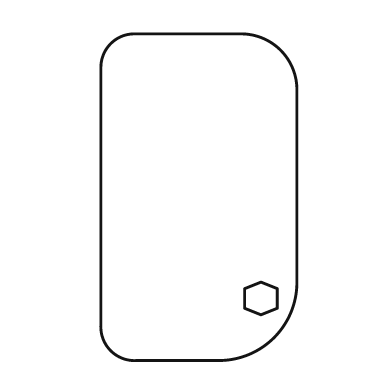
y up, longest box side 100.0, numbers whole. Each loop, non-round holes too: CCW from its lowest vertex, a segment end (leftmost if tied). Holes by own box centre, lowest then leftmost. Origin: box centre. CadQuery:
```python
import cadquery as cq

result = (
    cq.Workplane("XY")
    .moveTo(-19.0, -50.0)
    .lineTo(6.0, -50.0)
    .threePointArc((23.0, -43.0), (30.0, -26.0))
    .lineTo(30.0, 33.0)
    .threePointArc((25.0, 45.0), (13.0, 50.0))
    .lineTo(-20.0, 50.0)
    .threePointArc((-27.0, 47.0), (-30.0, 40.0))
    .lineTo(-30.0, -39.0)
    .threePointArc((-27.0, -47.0), (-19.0, -50.0))
    .close()
    .moveTo(19.0, -36.0)
    .lineTo(24.0, -34.0)
    .lineTo(24.0, -28.0)
    .lineTo(19.0, -26.0)
    .lineTo(14.0, -28.0)
    .lineTo(14.0, -34.0)
    .close()
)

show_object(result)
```